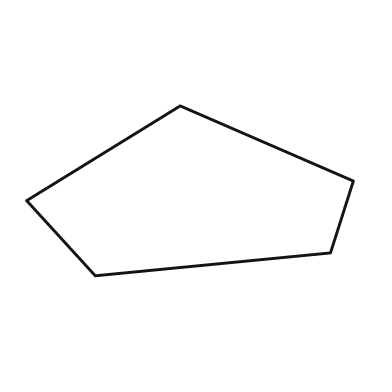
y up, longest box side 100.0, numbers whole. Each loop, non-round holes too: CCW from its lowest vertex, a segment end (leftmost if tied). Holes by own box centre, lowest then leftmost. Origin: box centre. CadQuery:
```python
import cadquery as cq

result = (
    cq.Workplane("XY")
    .moveTo(-29.0, -26.0)
    .lineTo(43.0, -19.0)
    .lineTo(50.0, 3.0)
    .lineTo(-3.0, 26.0)
    .lineTo(-50.0, -3.0)
    .close()
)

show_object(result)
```